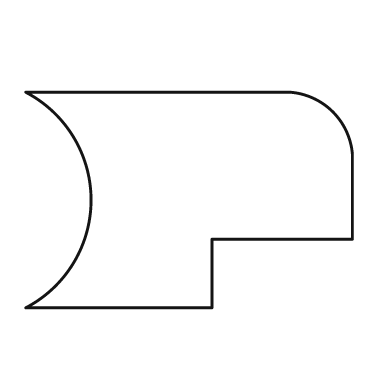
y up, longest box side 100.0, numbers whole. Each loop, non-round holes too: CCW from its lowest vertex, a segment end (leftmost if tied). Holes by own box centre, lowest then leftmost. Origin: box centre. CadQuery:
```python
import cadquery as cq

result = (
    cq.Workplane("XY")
    .moveTo(-50.0, -33.0)
    .lineTo(7.0, -33.0)
    .lineTo(7.0, -12.0)
    .lineTo(50.0, -12.0)
    .lineTo(50.0, 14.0)
    .threePointArc((44.0, 27.0), (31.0, 33.0))
    .lineTo(-50.0, 33.0)
    .threePointArc((-30.0, 0.0), (-50.0, -33.0))
    .close()
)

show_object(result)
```